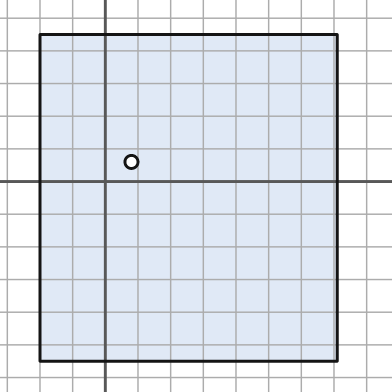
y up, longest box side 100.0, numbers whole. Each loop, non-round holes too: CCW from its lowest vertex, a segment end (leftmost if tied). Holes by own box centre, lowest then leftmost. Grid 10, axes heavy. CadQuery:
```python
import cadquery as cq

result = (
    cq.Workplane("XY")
    .moveTo(-20.0, -55.0)
    .lineTo(71.0, -55.0)
    .lineTo(71.0, 45.0)
    .lineTo(-20.0, 45.0)
    .close()
    .moveTo(8.0, 6.0)
    .circle(2.0)
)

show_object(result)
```